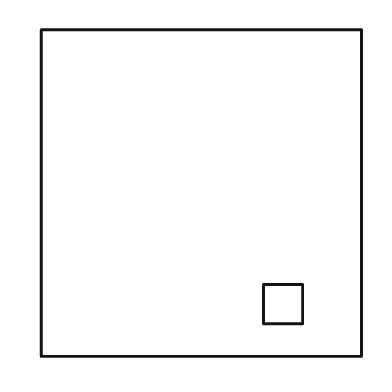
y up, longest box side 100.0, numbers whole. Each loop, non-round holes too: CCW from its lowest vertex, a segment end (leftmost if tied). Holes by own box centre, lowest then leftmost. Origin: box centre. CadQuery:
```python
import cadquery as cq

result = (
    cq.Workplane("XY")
    .moveTo(-49.0, -50.0)
    .lineTo(49.0, -50.0)
    .lineTo(49.0, 50.0)
    .lineTo(-49.0, 50.0)
    .close()
    .moveTo(19.0, -40.0)
    .lineTo(31.0, -40.0)
    .lineTo(31.0, -28.0)
    .lineTo(19.0, -28.0)
    .close()
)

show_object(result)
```